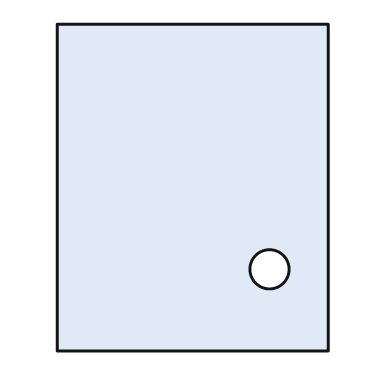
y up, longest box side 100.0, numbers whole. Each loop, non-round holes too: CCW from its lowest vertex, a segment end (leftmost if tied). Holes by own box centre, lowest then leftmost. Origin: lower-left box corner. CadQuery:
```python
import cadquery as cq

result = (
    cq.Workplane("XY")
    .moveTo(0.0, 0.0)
    .lineTo(83.0, 0.0)
    .lineTo(83.0, 100.0)
    .lineTo(0.0, 100.0)
    .close()
    .moveTo(65.0, 25.0)
    .circle(6.0)
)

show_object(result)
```